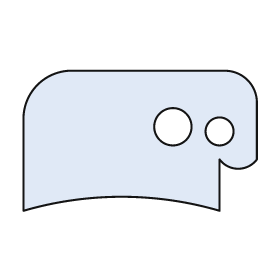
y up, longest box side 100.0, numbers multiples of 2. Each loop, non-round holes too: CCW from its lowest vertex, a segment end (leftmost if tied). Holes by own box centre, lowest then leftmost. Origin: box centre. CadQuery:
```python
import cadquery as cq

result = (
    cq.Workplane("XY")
    .moveTo(-50.0, -30.0)
    .threePointArc((-8.0, -24.0), (34.0, -30.0))
    .lineTo(34.0, -8.0)
    .threePointArc((42.0, -12.0), (50.0, -8.0))
    .lineTo(50.0, 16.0)
    .threePointArc((46.0, 26.0), (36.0, 30.0))
    .lineTo(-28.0, 30.0)
    .threePointArc((-44.0, 24.0), (-50.0, 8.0))
    .close()
    .moveTo(34.0, 4.0)
    .circle(6.0)
    .moveTo(14.0, 6.0)
    .circle(8.0)
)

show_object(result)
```